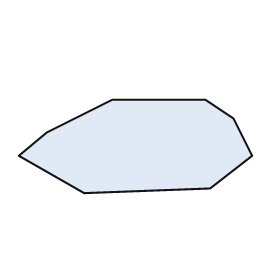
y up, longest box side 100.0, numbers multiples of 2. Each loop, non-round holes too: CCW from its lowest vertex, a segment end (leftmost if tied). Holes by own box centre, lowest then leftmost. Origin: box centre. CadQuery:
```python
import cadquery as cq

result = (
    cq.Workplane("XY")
    .moveTo(-22.0, -20.0)
    .lineTo(32.0, -18.0)
    .lineTo(50.0, -4.0)
    .lineTo(42.0, 12.0)
    .lineTo(30.0, 20.0)
    .lineTo(-10.0, 20.0)
    .lineTo(-38.0, 6.0)
    .lineTo(-50.0, -4.0)
    .close()
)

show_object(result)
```